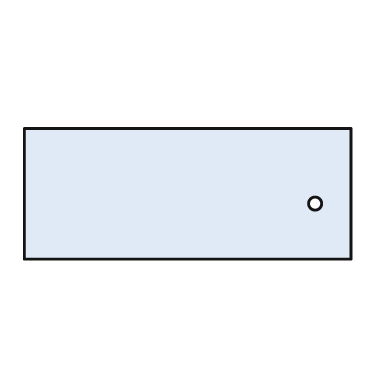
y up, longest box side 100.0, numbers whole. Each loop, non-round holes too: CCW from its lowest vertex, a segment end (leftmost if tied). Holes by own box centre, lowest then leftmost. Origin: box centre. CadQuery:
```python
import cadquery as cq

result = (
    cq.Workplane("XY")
    .moveTo(-50.0, -20.0)
    .lineTo(50.0, -20.0)
    .lineTo(50.0, 20.0)
    .lineTo(-50.0, 20.0)
    .close()
    .moveTo(39.0, -3.0)
    .circle(2.0)
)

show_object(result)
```